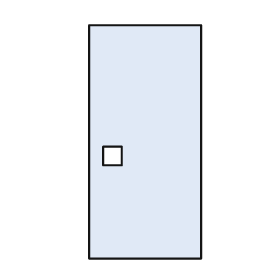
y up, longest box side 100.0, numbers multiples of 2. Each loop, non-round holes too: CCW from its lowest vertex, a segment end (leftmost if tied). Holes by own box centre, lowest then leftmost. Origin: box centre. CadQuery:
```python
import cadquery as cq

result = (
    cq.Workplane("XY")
    .moveTo(-24.0, -50.0)
    .lineTo(24.0, -50.0)
    .lineTo(24.0, 50.0)
    .lineTo(-24.0, 50.0)
    .close()
    .moveTo(-18.0, -10.0)
    .lineTo(-10.0, -10.0)
    .lineTo(-10.0, -2.0)
    .lineTo(-18.0, -2.0)
    .close()
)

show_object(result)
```